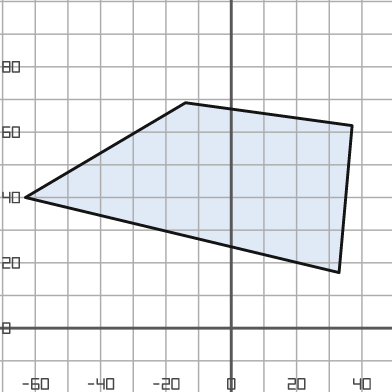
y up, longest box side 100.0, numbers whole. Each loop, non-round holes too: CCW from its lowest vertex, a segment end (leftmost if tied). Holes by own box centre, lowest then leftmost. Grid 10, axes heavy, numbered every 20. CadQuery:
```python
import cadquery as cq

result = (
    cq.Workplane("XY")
    .moveTo(33.0, 17.0)
    .lineTo(37.0, 62.0)
    .lineTo(-14.0, 69.0)
    .lineTo(-63.0, 40.0)
    .close()
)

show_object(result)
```